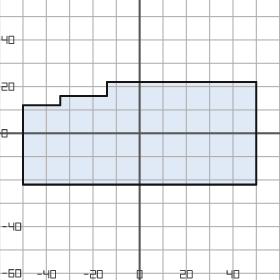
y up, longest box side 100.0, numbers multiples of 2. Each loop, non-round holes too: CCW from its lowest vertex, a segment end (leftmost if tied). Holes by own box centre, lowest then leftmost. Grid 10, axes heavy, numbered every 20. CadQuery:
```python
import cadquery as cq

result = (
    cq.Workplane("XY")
    .moveTo(-50.0, -22.0)
    .lineTo(50.0, -22.0)
    .lineTo(50.0, 22.0)
    .lineTo(-14.0, 22.0)
    .lineTo(-14.0, 16.0)
    .lineTo(-34.0, 16.0)
    .lineTo(-34.0, 12.0)
    .lineTo(-50.0, 12.0)
    .close()
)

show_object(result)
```